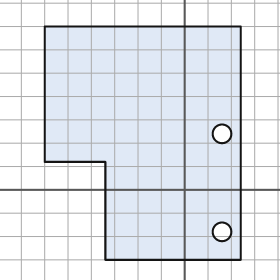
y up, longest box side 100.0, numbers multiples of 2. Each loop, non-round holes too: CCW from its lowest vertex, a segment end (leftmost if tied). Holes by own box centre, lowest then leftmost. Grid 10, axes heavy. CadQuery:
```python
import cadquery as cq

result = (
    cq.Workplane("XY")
    .moveTo(-34.0, -30.0)
    .lineTo(24.0, -30.0)
    .lineTo(24.0, 70.0)
    .lineTo(-60.0, 70.0)
    .lineTo(-60.0, 12.0)
    .lineTo(-34.0, 12.0)
    .close()
    .moveTo(16.0, -18.0)
    .circle(4.0)
    .moveTo(16.0, 24.0)
    .circle(4.0)
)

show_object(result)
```